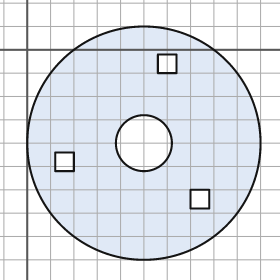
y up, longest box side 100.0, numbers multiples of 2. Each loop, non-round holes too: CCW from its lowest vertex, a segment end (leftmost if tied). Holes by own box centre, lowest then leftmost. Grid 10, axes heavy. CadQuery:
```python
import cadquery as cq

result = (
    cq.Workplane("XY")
    .moveTo(50.0, -40.0)
    .circle(50.0)
    .moveTo(70.0, -68.0)
    .lineTo(78.0, -68.0)
    .lineTo(78.0, -60.0)
    .lineTo(70.0, -60.0)
    .close()
    .moveTo(12.0, -52.0)
    .lineTo(20.0, -52.0)
    .lineTo(20.0, -44.0)
    .lineTo(12.0, -44.0)
    .close()
    .moveTo(50.0, -40.0)
    .circle(12.0)
    .moveTo(56.0, -10.0)
    .lineTo(64.0, -10.0)
    .lineTo(64.0, -2.0)
    .lineTo(56.0, -2.0)
    .close()
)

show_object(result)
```